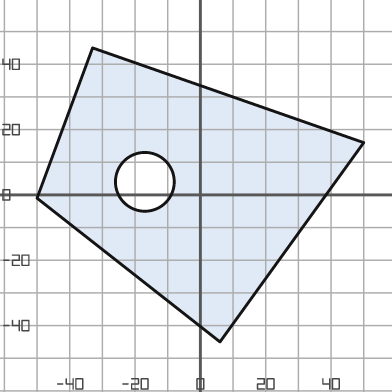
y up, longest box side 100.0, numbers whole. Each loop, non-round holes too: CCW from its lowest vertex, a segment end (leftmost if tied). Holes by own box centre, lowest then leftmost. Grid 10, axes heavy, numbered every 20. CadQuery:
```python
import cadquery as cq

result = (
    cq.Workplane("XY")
    .moveTo(6.0, -45.0)
    .lineTo(50.0, 16.0)
    .lineTo(-33.0, 45.0)
    .lineTo(-50.0, -1.0)
    .close()
    .moveTo(-17.0, 4.0)
    .circle(9.0)
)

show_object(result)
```